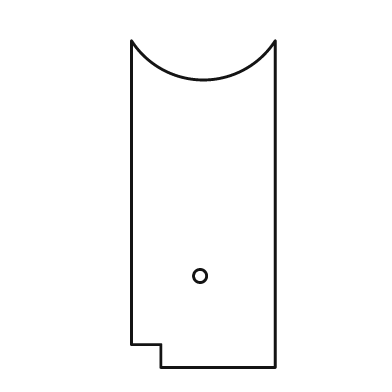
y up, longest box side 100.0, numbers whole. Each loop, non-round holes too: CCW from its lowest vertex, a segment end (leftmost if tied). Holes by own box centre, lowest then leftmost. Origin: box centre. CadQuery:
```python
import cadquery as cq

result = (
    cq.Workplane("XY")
    .moveTo(-13.0, -50.0)
    .lineTo(22.0, -50.0)
    .lineTo(22.0, 50.0)
    .threePointArc((0.0, 38.0), (-22.0, 50.0))
    .lineTo(-22.0, -43.0)
    .lineTo(-13.0, -43.0)
    .close()
    .moveTo(-1.0, -22.0)
    .circle(2.0)
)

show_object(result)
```